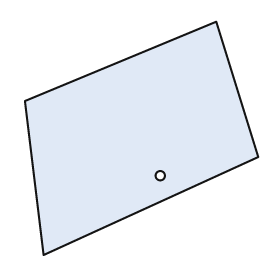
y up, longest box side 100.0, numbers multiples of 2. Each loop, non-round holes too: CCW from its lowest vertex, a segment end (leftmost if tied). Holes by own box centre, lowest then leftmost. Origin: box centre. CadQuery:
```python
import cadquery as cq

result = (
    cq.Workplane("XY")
    .moveTo(-42.0, -50.0)
    .lineTo(50.0, -8.0)
    .lineTo(32.0, 50.0)
    .lineTo(-50.0, 16.0)
    .close()
    .moveTo(8.0, -16.0)
    .circle(2.0)
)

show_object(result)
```